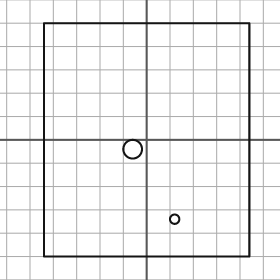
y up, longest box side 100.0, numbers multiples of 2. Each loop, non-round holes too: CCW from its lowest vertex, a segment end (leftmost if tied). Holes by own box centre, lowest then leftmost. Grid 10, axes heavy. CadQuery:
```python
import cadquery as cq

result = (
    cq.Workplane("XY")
    .moveTo(-44.0, -50.0)
    .lineTo(44.0, -50.0)
    .lineTo(44.0, 50.0)
    .lineTo(-44.0, 50.0)
    .close()
    .moveTo(12.0, -34.0)
    .circle(2.0)
    .moveTo(-6.0, -4.0)
    .circle(4.0)
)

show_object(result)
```